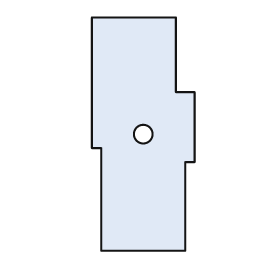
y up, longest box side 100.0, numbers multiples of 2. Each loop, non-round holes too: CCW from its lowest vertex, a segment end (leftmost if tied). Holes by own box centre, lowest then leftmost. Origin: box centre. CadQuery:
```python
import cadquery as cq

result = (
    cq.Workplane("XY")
    .moveTo(-18.0, -50.0)
    .lineTo(18.0, -50.0)
    .lineTo(18.0, -12.0)
    .lineTo(22.0, -12.0)
    .lineTo(22.0, 18.0)
    .lineTo(14.0, 18.0)
    .lineTo(14.0, 50.0)
    .lineTo(-22.0, 50.0)
    .lineTo(-22.0, -6.0)
    .lineTo(-18.0, -6.0)
    .close()
    .moveTo(0.0, 0.0)
    .circle(4.0)
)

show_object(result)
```